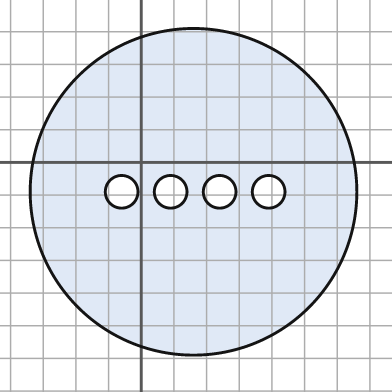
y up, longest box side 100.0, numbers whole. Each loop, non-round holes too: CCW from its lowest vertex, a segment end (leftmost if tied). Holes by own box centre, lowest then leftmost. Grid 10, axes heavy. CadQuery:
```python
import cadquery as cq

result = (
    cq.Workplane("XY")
    .moveTo(16.0, -9.0)
    .circle(50.0)
    .moveTo(-6.0, -9.0)
    .circle(5.0)
    .moveTo(9.0, -9.0)
    .circle(5.0)
    .moveTo(24.0, -9.0)
    .circle(5.0)
    .moveTo(39.0, -9.0)
    .circle(5.0)
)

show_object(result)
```